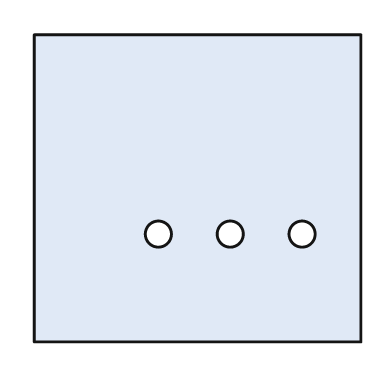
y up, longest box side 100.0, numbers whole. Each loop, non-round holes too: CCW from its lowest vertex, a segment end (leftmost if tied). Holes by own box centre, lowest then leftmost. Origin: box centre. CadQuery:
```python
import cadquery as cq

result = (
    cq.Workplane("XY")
    .moveTo(-50.0, -47.0)
    .lineTo(50.0, -47.0)
    .lineTo(50.0, 47.0)
    .lineTo(-50.0, 47.0)
    .close()
    .moveTo(-12.0, -14.0)
    .circle(4.0)
    .moveTo(10.0, -14.0)
    .circle(4.0)
    .moveTo(32.0, -14.0)
    .circle(4.0)
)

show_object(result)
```